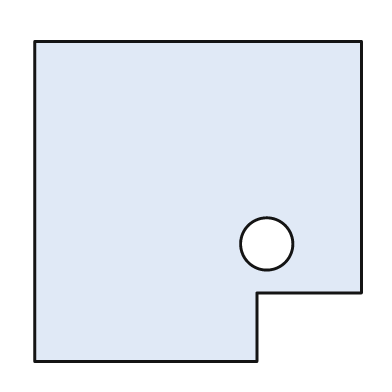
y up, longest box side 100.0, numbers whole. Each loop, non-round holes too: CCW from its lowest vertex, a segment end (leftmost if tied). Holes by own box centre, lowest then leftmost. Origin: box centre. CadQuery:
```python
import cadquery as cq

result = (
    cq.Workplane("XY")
    .moveTo(-50.0, -49.0)
    .lineTo(18.0, -49.0)
    .lineTo(18.0, -28.0)
    .lineTo(50.0, -28.0)
    .lineTo(50.0, 49.0)
    .lineTo(-50.0, 49.0)
    .close()
    .moveTo(21.0, -13.0)
    .circle(8.0)
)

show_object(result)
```